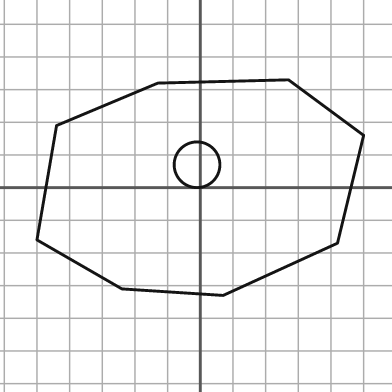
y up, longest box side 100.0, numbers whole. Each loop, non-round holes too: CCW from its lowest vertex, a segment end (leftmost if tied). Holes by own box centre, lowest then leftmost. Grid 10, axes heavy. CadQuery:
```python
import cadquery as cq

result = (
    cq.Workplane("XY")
    .moveTo(7.0, -33.0)
    .lineTo(42.0, -17.0)
    .lineTo(50.0, 16.0)
    .lineTo(27.0, 33.0)
    .lineTo(-13.0, 32.0)
    .lineTo(-44.0, 19.0)
    .lineTo(-50.0, -16.0)
    .lineTo(-24.0, -31.0)
    .close()
    .moveTo(-1.0, 7.0)
    .circle(7.0)
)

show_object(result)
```